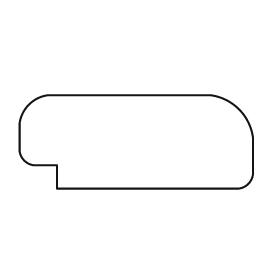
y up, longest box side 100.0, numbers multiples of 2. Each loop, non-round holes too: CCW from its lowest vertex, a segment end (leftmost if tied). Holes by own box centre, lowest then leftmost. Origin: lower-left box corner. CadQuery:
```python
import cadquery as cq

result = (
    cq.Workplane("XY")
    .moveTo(16.0, 0.0)
    .lineTo(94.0, 0.0)
    .threePointArc((98.0, 2.0), (100.0, 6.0))
    .lineTo(100.0, 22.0)
    .threePointArc((94.0, 34.0), (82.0, 40.0))
    .lineTo(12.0, 40.0)
    .threePointArc((4.0, 36.0), (0.0, 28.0))
    .lineTo(0.0, 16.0)
    .threePointArc((2.0, 12.0), (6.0, 10.0))
    .lineTo(16.0, 10.0)
    .close()
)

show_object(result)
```